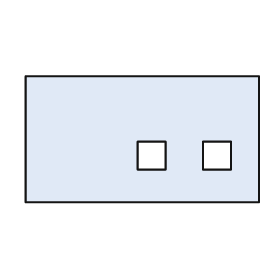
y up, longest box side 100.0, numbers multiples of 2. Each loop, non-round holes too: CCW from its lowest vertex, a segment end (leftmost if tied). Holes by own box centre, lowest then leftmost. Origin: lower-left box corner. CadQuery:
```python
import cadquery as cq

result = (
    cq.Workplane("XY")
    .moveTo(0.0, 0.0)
    .lineTo(100.0, 0.0)
    .lineTo(100.0, 54.0)
    .lineTo(0.0, 54.0)
    .close()
    .moveTo(48.0, 14.0)
    .lineTo(60.0, 14.0)
    .lineTo(60.0, 26.0)
    .lineTo(48.0, 26.0)
    .close()
    .moveTo(76.0, 14.0)
    .lineTo(88.0, 14.0)
    .lineTo(88.0, 26.0)
    .lineTo(76.0, 26.0)
    .close()
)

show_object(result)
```